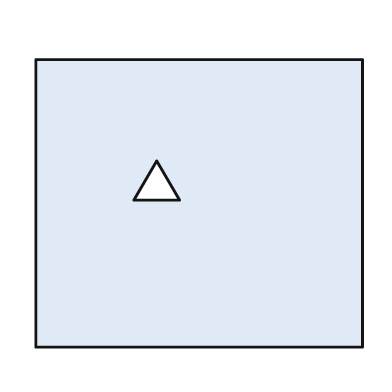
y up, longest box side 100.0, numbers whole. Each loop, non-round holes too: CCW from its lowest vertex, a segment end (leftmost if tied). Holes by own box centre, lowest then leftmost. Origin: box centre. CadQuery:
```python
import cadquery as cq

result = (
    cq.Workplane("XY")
    .moveTo(-50.0, -44.0)
    .lineTo(50.0, -44.0)
    .lineTo(50.0, 44.0)
    .lineTo(-50.0, 44.0)
    .close()
    .moveTo(-20.0, 1.0)
    .lineTo(-6.0, 1.0)
    .lineTo(-13.0, 13.0)
    .close()
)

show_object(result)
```